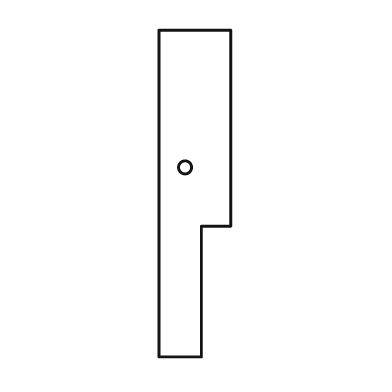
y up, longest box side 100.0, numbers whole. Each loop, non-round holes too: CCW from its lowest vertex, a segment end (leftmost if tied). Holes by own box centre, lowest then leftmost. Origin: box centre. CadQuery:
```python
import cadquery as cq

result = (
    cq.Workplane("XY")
    .moveTo(-11.0, -50.0)
    .lineTo(2.0, -50.0)
    .lineTo(2.0, -10.0)
    .lineTo(11.0, -10.0)
    .lineTo(11.0, 50.0)
    .lineTo(-11.0, 50.0)
    .close()
    .moveTo(-3.0, 8.0)
    .circle(2.0)
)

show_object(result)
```